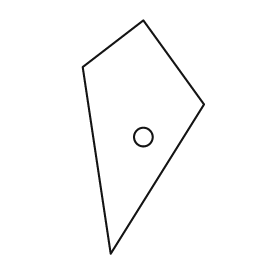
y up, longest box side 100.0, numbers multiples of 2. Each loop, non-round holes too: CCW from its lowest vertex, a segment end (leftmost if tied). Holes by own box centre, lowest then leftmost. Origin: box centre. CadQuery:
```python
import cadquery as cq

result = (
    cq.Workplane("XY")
    .moveTo(-14.0, -50.0)
    .lineTo(26.0, 14.0)
    .lineTo(0.0, 50.0)
    .lineTo(-26.0, 30.0)
    .close()
    .moveTo(0.0, 0.0)
    .circle(4.0)
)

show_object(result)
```